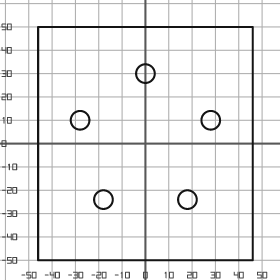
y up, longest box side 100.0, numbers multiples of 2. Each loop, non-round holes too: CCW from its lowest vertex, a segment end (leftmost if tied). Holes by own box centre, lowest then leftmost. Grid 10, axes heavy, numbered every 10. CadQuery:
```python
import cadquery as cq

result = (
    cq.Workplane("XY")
    .moveTo(-46.0, -50.0)
    .lineTo(46.0, -50.0)
    .lineTo(46.0, 50.0)
    .lineTo(-46.0, 50.0)
    .close()
    .moveTo(-18.0, -24.0)
    .circle(4.0)
    .moveTo(18.0, -24.0)
    .circle(4.0)
    .moveTo(-28.0, 10.0)
    .circle(4.0)
    .moveTo(28.0, 10.0)
    .circle(4.0)
    .moveTo(0.0, 30.0)
    .circle(4.0)
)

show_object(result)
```